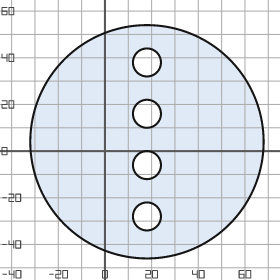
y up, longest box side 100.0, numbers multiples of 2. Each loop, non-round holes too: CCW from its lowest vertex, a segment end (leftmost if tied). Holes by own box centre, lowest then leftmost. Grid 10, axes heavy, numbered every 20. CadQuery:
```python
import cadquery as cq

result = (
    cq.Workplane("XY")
    .moveTo(18.0, 4.0)
    .circle(50.0)
    .moveTo(18.0, -28.0)
    .circle(6.0)
    .moveTo(18.0, -6.0)
    .circle(6.0)
    .moveTo(18.0, 16.0)
    .circle(6.0)
    .moveTo(18.0, 38.0)
    .circle(6.0)
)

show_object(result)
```